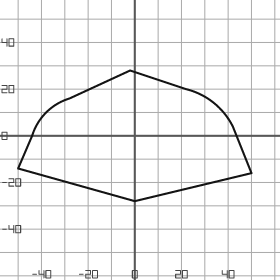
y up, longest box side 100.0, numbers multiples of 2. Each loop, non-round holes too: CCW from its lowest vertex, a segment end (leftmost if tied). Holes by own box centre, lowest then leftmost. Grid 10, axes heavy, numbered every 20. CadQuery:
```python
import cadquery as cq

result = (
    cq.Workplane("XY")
    .moveTo(0.0, -28.0)
    .lineTo(50.0, -16.0)
    .lineTo(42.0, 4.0)
    .threePointArc((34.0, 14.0), (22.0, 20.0))
    .lineTo(-2.0, 28.0)
    .lineTo(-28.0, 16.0)
    .threePointArc((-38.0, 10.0), (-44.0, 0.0))
    .lineTo(-50.0, -14.0)
    .close()
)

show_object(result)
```